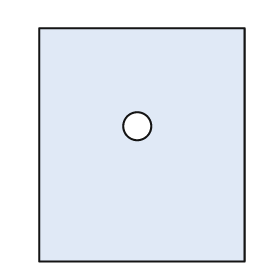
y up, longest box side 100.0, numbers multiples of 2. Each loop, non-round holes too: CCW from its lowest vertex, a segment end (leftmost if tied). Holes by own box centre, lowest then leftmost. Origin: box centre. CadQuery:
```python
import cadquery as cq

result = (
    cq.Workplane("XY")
    .moveTo(-44.0, -50.0)
    .lineTo(44.0, -50.0)
    .lineTo(44.0, 50.0)
    .lineTo(-44.0, 50.0)
    .close()
    .moveTo(-2.0, 8.0)
    .circle(6.0)
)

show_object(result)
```